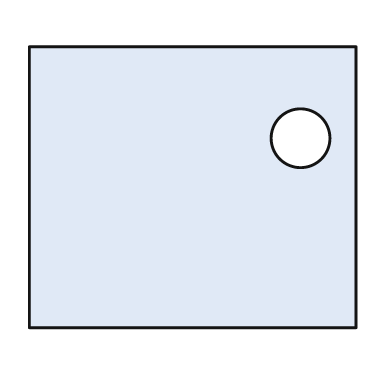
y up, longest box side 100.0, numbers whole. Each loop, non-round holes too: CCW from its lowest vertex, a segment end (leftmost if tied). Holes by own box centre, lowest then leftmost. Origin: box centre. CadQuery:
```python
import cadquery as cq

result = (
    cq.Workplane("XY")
    .moveTo(-50.0, -43.0)
    .lineTo(50.0, -43.0)
    .lineTo(50.0, 43.0)
    .lineTo(-50.0, 43.0)
    .close()
    .moveTo(33.0, 15.0)
    .circle(9.0)
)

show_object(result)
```